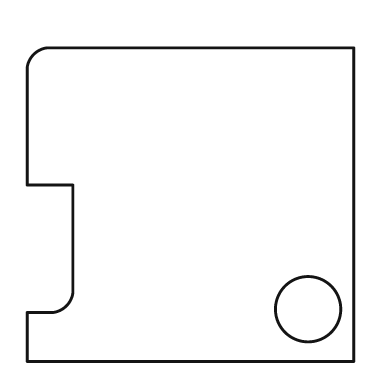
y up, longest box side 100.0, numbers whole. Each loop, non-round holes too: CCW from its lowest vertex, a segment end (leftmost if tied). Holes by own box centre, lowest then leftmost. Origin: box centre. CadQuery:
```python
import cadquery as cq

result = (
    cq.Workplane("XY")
    .moveTo(-50.0, -48.0)
    .lineTo(50.0, -48.0)
    .lineTo(50.0, 48.0)
    .lineTo(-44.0, 48.0)
    .threePointArc((-48.0, 46.0), (-50.0, 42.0))
    .lineTo(-50.0, 6.0)
    .lineTo(-36.0, 6.0)
    .lineTo(-36.0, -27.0)
    .threePointArc((-38.0, -31.0), (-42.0, -33.0))
    .lineTo(-50.0, -33.0)
    .close()
    .moveTo(36.0, -32.0)
    .circle(10.0)
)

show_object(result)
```